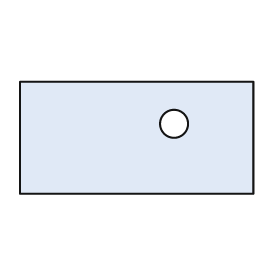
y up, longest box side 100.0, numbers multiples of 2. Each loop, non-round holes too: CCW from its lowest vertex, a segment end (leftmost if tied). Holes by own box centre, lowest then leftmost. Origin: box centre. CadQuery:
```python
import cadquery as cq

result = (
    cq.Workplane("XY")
    .moveTo(-50.0, -24.0)
    .lineTo(50.0, -24.0)
    .lineTo(50.0, 24.0)
    .lineTo(-50.0, 24.0)
    .close()
    .moveTo(16.0, 6.0)
    .circle(6.0)
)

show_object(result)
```